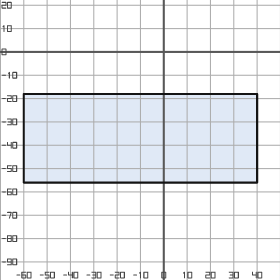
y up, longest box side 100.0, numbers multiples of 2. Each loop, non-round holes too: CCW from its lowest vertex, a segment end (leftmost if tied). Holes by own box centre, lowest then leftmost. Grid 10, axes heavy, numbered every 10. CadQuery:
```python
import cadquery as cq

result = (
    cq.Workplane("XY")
    .moveTo(-60.0, -56.0)
    .lineTo(40.0, -56.0)
    .lineTo(40.0, -18.0)
    .lineTo(-60.0, -18.0)
    .close()
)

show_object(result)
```